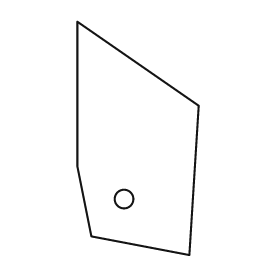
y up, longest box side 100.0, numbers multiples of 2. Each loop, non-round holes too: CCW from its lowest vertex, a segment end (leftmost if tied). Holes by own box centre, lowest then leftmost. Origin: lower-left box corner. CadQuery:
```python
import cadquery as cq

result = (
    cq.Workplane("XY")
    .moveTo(48.0, 0.0)
    .lineTo(52.0, 64.0)
    .lineTo(0.0, 100.0)
    .lineTo(0.0, 38.0)
    .lineTo(6.0, 8.0)
    .close()
    .moveTo(20.0, 24.0)
    .circle(4.0)
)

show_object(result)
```